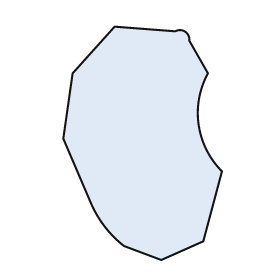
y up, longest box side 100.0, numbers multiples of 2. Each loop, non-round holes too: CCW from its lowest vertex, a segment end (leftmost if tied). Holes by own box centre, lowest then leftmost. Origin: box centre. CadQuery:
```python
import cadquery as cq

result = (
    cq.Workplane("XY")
    .moveTo(8.0, -50.0)
    .lineTo(26.0, -42.0)
    .lineTo(34.0, -12.0)
    .threePointArc((24.0, 8.0), (28.0, 30.0))
    .lineTo(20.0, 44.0)
    .threePointArc((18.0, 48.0), (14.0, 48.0))
    .lineTo(-12.0, 50.0)
    .lineTo(-30.0, 30.0)
    .lineTo(-34.0, 2.0)
    .lineTo(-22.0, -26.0)
    .threePointArc((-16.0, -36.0), (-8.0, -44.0))
    .close()
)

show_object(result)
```